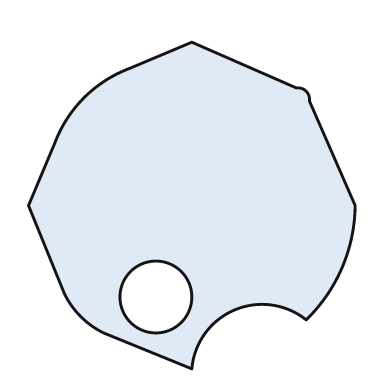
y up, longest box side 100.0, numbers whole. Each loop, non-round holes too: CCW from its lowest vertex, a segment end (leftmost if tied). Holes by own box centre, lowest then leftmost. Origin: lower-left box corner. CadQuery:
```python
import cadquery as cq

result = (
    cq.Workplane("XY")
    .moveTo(50.0, 0.0)
    .threePointArc((63.0, 18.0), (85.0, 15.0))
    .threePointArc((96.0, 31.0), (100.0, 50.0))
    .lineTo(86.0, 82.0)
    .threePointArc((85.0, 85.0), (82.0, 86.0))
    .lineTo(50.0, 100.0)
    .lineTo(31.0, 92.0)
    .threePointArc((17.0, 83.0), (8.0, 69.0))
    .lineTo(0.0, 50.0)
    .lineTo(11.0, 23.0)
    .threePointArc((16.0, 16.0), (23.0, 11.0))
    .close()
    .moveTo(39.0, 22.0)
    .circle(11.0)
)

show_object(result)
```